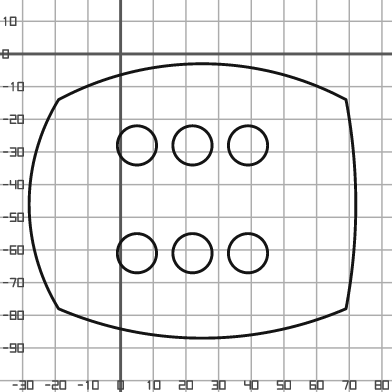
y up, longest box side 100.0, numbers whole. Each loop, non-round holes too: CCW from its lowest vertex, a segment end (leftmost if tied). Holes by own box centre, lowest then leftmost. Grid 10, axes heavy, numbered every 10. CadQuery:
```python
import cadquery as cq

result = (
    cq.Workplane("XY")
    .moveTo(-19.0, -78.0)
    .threePointArc((25.0, -87.0), (69.0, -78.0))
    .threePointArc((72.0, -46.0), (69.0, -14.0))
    .threePointArc((25.0, -3.0), (-19.0, -14.0))
    .threePointArc((-28.0, -46.0), (-19.0, -78.0))
    .close()
    .moveTo(5.0, -61.0)
    .circle(6.0)
    .moveTo(22.0, -61.0)
    .circle(6.0)
    .moveTo(39.0, -61.0)
    .circle(6.0)
    .moveTo(5.0, -28.0)
    .circle(6.0)
    .moveTo(22.0, -28.0)
    .circle(6.0)
    .moveTo(39.0, -28.0)
    .circle(6.0)
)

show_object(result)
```